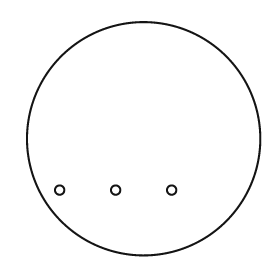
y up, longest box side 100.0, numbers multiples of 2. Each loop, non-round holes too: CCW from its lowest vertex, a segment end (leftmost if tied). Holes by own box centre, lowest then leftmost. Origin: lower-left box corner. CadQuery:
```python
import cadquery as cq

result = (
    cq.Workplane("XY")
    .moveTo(50.0, 50.0)
    .circle(50.0)
    .moveTo(14.0, 28.0)
    .circle(2.0)
    .moveTo(38.0, 28.0)
    .circle(2.0)
    .moveTo(62.0, 28.0)
    .circle(2.0)
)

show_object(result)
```